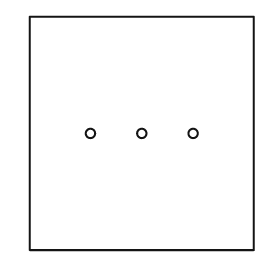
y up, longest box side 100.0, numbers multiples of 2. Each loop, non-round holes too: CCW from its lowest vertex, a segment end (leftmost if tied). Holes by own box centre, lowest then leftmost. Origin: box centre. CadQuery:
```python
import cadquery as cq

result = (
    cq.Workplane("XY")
    .moveTo(-48.0, -50.0)
    .lineTo(48.0, -50.0)
    .lineTo(48.0, 50.0)
    .lineTo(-48.0, 50.0)
    .close()
    .moveTo(-22.0, 0.0)
    .circle(2.0)
    .moveTo(0.0, 0.0)
    .circle(2.0)
    .moveTo(22.0, 0.0)
    .circle(2.0)
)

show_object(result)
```